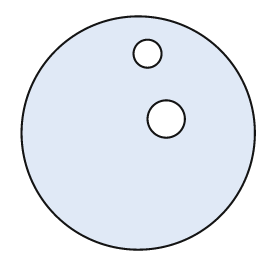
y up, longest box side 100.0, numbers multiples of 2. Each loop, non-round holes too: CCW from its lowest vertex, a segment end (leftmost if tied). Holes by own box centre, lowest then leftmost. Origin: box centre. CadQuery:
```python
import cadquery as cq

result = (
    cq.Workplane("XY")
    .moveTo(0.0, 0.0)
    .circle(50.0)
    .moveTo(12.0, 6.0)
    .circle(8.0)
    .moveTo(4.0, 34.0)
    .circle(6.0)
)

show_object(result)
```